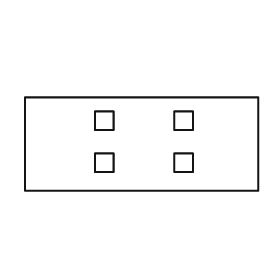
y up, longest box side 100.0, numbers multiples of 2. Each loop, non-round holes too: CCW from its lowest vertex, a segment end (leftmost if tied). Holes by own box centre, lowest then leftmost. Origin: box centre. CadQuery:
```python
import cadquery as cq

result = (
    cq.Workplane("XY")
    .moveTo(-50.0, -20.0)
    .lineTo(50.0, -20.0)
    .lineTo(50.0, 20.0)
    .lineTo(-50.0, 20.0)
    .close()
    .moveTo(-20.0, -12.0)
    .lineTo(-12.0, -12.0)
    .lineTo(-12.0, -4.0)
    .lineTo(-20.0, -4.0)
    .close()
    .moveTo(14.0, -12.0)
    .lineTo(22.0, -12.0)
    .lineTo(22.0, -4.0)
    .lineTo(14.0, -4.0)
    .close()
    .moveTo(-20.0, 6.0)
    .lineTo(-12.0, 6.0)
    .lineTo(-12.0, 14.0)
    .lineTo(-20.0, 14.0)
    .close()
    .moveTo(14.0, 6.0)
    .lineTo(22.0, 6.0)
    .lineTo(22.0, 14.0)
    .lineTo(14.0, 14.0)
    .close()
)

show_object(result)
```